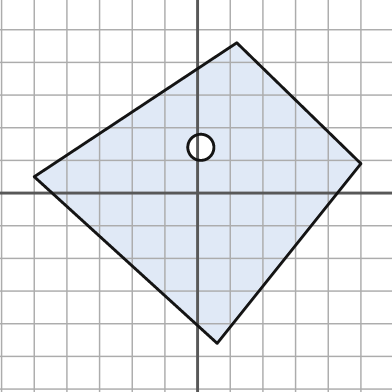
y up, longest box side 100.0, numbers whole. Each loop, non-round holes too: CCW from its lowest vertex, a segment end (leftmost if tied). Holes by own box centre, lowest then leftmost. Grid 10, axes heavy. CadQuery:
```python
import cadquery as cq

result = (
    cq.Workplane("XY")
    .moveTo(6.0, -46.0)
    .lineTo(50.0, 9.0)
    .lineTo(12.0, 46.0)
    .lineTo(-50.0, 5.0)
    .close()
    .moveTo(1.0, 14.0)
    .circle(4.0)
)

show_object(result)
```